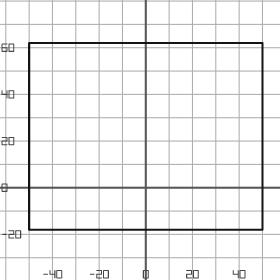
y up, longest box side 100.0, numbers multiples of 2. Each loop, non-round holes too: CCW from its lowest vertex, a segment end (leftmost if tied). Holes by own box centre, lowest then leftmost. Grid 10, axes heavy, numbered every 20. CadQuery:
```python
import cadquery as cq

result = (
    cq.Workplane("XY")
    .moveTo(-50.0, -18.0)
    .lineTo(50.0, -18.0)
    .lineTo(50.0, 62.0)
    .lineTo(-50.0, 62.0)
    .close()
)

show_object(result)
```